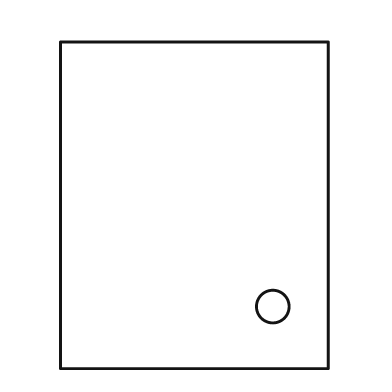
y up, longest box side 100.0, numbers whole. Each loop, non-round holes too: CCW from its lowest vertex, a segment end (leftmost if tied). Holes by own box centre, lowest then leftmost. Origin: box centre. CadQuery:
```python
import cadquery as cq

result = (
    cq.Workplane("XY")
    .moveTo(-41.0, -50.0)
    .lineTo(41.0, -50.0)
    .lineTo(41.0, 50.0)
    .lineTo(-41.0, 50.0)
    .close()
    .moveTo(24.0, -31.0)
    .circle(5.0)
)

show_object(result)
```